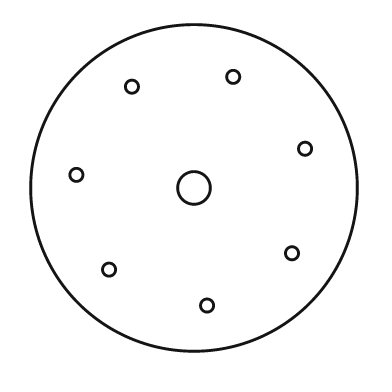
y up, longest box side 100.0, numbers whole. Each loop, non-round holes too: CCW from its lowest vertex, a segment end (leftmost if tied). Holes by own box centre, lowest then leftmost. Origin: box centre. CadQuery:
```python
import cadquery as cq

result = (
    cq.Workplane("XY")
    .moveTo(0.0, 0.0)
    .circle(50.0)
    .moveTo(4.0, -36.0)
    .circle(2.0)
    .moveTo(-26.0, -25.0)
    .circle(2.0)
    .moveTo(30.0, -20.0)
    .circle(2.0)
    .moveTo(0.0, 0.0)
    .circle(5.0)
    .moveTo(-36.0, 4.0)
    .circle(2.0)
    .moveTo(34.0, 12.0)
    .circle(2.0)
    .moveTo(-19.0, 31.0)
    .circle(2.0)
    .moveTo(12.0, 34.0)
    .circle(2.0)
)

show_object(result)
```